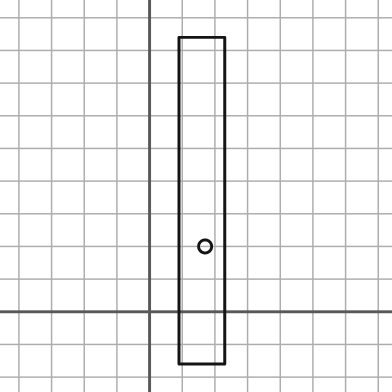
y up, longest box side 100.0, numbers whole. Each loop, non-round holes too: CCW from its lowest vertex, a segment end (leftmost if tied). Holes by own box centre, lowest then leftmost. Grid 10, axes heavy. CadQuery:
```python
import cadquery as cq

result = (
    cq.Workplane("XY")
    .moveTo(9.0, -16.0)
    .lineTo(23.0, -16.0)
    .lineTo(23.0, 84.0)
    .lineTo(9.0, 84.0)
    .close()
    .moveTo(17.0, 20.0)
    .circle(2.0)
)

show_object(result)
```